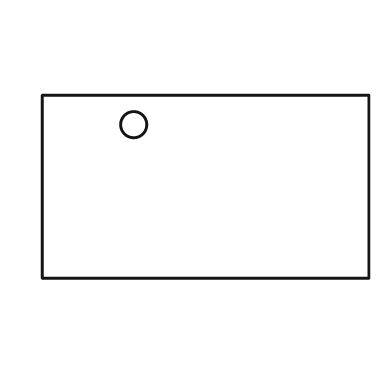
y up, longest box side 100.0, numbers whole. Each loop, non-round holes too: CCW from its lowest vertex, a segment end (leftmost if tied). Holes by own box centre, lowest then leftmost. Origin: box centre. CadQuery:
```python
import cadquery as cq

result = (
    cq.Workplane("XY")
    .moveTo(-50.0, -28.0)
    .lineTo(50.0, -28.0)
    .lineTo(50.0, 28.0)
    .lineTo(-50.0, 28.0)
    .close()
    .moveTo(-22.0, 19.0)
    .circle(4.0)
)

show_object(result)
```